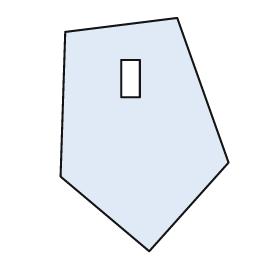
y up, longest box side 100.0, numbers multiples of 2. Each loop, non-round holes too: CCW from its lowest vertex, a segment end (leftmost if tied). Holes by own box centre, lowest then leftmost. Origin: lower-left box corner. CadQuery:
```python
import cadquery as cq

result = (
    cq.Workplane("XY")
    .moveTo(38.0, 0.0)
    .lineTo(72.0, 38.0)
    .lineTo(50.0, 100.0)
    .lineTo(2.0, 94.0)
    .lineTo(0.0, 32.0)
    .close()
    .moveTo(26.0, 66.0)
    .lineTo(34.0, 66.0)
    .lineTo(34.0, 82.0)
    .lineTo(26.0, 82.0)
    .close()
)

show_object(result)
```